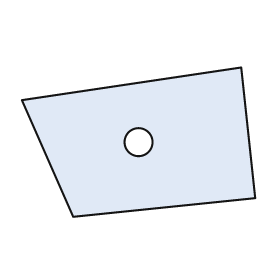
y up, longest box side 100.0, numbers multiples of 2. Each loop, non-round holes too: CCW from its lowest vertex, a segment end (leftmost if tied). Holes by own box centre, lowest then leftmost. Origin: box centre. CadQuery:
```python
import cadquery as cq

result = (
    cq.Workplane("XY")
    .moveTo(-28.0, -32.0)
    .lineTo(50.0, -24.0)
    .lineTo(44.0, 32.0)
    .lineTo(-50.0, 18.0)
    .close()
    .moveTo(0.0, 0.0)
    .circle(6.0)
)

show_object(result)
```